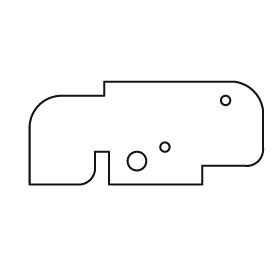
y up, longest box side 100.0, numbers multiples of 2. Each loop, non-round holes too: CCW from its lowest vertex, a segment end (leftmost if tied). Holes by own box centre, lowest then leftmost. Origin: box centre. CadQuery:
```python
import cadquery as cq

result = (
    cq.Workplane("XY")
    .moveTo(-50.0, -22.0)
    .lineTo(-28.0, -22.0)
    .threePointArc((-24.0, -20.0), (-22.0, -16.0))
    .lineTo(-22.0, -8.0)
    .lineTo(-16.0, -8.0)
    .lineTo(-16.0, -22.0)
    .lineTo(24.0, -22.0)
    .lineTo(24.0, -14.0)
    .lineTo(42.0, -14.0)
    .threePointArc((48.0, -12.0), (50.0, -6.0))
    .lineTo(50.0, 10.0)
    .threePointArc((46.0, 18.0), (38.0, 22.0))
    .lineTo(-18.0, 22.0)
    .lineTo(-18.0, 16.0)
    .lineTo(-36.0, 16.0)
    .threePointArc((-46.0, 12.0), (-50.0, 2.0))
    .close()
    .moveTo(-4.0, -12.0)
    .circle(4.0)
    .moveTo(8.0, -6.0)
    .circle(2.0)
    .moveTo(34.0, 14.0)
    .circle(2.0)
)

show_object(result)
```